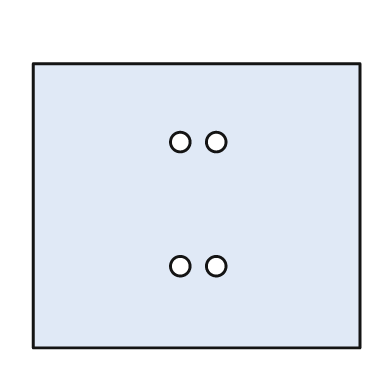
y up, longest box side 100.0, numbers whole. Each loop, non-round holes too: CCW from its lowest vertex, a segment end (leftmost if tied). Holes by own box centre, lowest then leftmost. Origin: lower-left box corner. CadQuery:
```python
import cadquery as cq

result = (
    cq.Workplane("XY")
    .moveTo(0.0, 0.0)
    .lineTo(100.0, 0.0)
    .lineTo(100.0, 87.0)
    .lineTo(0.0, 87.0)
    .close()
    .moveTo(45.0, 25.0)
    .circle(3.0)
    .moveTo(56.0, 25.0)
    .circle(3.0)
    .moveTo(45.0, 63.0)
    .circle(3.0)
    .moveTo(56.0, 63.0)
    .circle(3.0)
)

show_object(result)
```